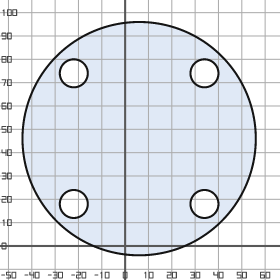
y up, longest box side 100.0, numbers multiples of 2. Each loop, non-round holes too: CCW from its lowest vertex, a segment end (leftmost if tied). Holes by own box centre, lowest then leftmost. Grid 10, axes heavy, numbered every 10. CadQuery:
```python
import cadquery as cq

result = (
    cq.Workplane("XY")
    .moveTo(6.0, 46.0)
    .circle(50.0)
    .moveTo(-22.0, 18.0)
    .circle(6.0)
    .moveTo(34.0, 18.0)
    .circle(6.0)
    .moveTo(-22.0, 74.0)
    .circle(6.0)
    .moveTo(34.0, 74.0)
    .circle(6.0)
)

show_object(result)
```